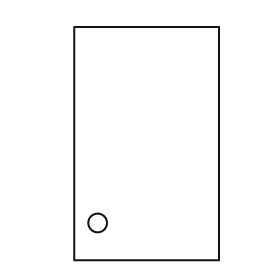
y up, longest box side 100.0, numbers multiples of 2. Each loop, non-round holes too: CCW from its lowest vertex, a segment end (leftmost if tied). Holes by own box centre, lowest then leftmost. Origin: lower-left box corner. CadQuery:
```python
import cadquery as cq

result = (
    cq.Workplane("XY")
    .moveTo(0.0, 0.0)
    .lineTo(62.0, 0.0)
    .lineTo(62.0, 100.0)
    .lineTo(0.0, 100.0)
    .close()
    .moveTo(10.0, 16.0)
    .circle(4.0)
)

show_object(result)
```